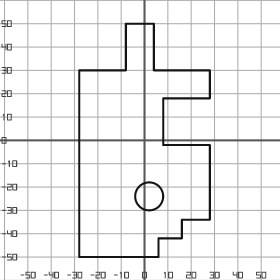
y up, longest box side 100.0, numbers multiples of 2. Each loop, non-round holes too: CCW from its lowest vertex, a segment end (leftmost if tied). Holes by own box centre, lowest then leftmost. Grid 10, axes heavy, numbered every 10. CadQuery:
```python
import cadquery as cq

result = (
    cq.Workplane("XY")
    .moveTo(-28.0, -50.0)
    .lineTo(6.0, -50.0)
    .lineTo(6.0, -42.0)
    .lineTo(16.0, -42.0)
    .lineTo(16.0, -34.0)
    .lineTo(28.0, -34.0)
    .lineTo(28.0, -2.0)
    .lineTo(8.0, -2.0)
    .lineTo(8.0, 18.0)
    .lineTo(28.0, 18.0)
    .lineTo(28.0, 30.0)
    .lineTo(4.0, 30.0)
    .lineTo(4.0, 50.0)
    .lineTo(-8.0, 50.0)
    .lineTo(-8.0, 30.0)
    .lineTo(-28.0, 30.0)
    .close()
    .moveTo(2.0, -24.0)
    .circle(6.0)
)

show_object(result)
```